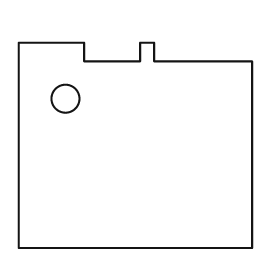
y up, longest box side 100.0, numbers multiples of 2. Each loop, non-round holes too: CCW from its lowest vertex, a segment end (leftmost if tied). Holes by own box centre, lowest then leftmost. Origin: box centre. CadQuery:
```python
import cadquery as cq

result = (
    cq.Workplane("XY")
    .moveTo(-50.0, -44.0)
    .lineTo(50.0, -44.0)
    .lineTo(50.0, 36.0)
    .lineTo(8.0, 36.0)
    .lineTo(8.0, 44.0)
    .lineTo(2.0, 44.0)
    .lineTo(2.0, 36.0)
    .lineTo(-22.0, 36.0)
    .lineTo(-22.0, 44.0)
    .lineTo(-50.0, 44.0)
    .close()
    .moveTo(-30.0, 20.0)
    .circle(6.0)
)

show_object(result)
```